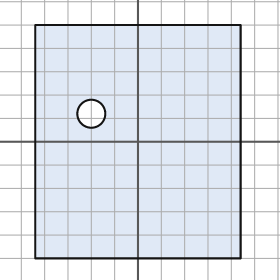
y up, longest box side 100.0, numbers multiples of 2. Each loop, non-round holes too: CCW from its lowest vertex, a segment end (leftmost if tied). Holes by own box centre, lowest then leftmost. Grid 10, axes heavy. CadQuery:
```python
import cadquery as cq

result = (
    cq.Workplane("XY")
    .moveTo(-44.0, -50.0)
    .lineTo(44.0, -50.0)
    .lineTo(44.0, 50.0)
    .lineTo(-44.0, 50.0)
    .close()
    .moveTo(-20.0, 12.0)
    .circle(6.0)
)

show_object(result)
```